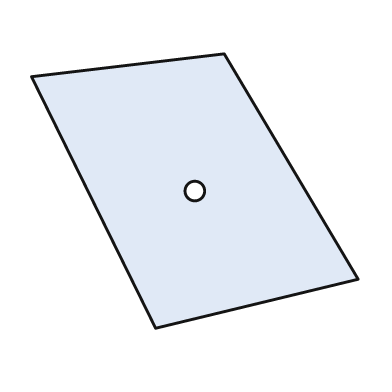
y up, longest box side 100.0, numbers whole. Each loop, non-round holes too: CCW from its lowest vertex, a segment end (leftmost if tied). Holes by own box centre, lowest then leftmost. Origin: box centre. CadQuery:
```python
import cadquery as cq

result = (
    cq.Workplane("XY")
    .moveTo(-12.0, -42.0)
    .lineTo(50.0, -27.0)
    .lineTo(9.0, 42.0)
    .lineTo(-50.0, 35.0)
    .close()
    .moveTo(0.0, 0.0)
    .circle(3.0)
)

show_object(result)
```